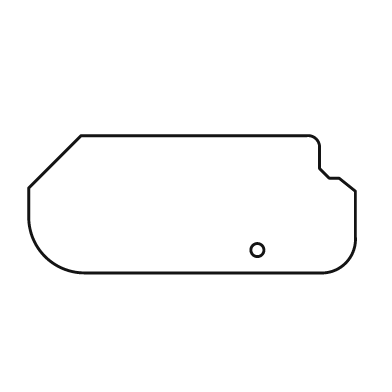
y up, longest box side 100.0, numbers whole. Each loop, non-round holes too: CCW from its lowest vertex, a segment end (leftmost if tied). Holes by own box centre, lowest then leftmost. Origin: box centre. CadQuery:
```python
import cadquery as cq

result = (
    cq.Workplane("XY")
    .moveTo(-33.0, -21.0)
    .lineTo(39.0, -21.0)
    .threePointArc((47.0, -18.0), (50.0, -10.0))
    .lineTo(50.0, 4.0)
    .lineTo(45.0, 8.0)
    .lineTo(42.0, 8.0)
    .lineTo(39.0, 11.0)
    .lineTo(39.0, 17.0)
    .threePointArc((38.0, 20.0), (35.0, 21.0))
    .lineTo(-34.0, 21.0)
    .lineTo(-50.0, 5.0)
    .lineTo(-50.0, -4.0)
    .threePointArc((-45.0, -16.0), (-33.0, -21.0))
    .close()
    .moveTo(20.0, -14.0)
    .circle(2.0)
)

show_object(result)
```